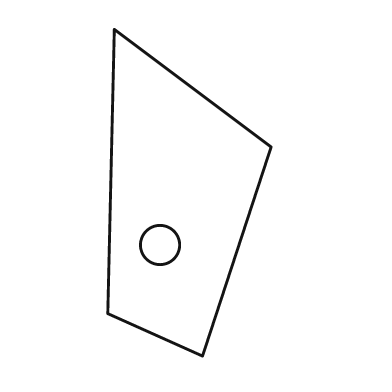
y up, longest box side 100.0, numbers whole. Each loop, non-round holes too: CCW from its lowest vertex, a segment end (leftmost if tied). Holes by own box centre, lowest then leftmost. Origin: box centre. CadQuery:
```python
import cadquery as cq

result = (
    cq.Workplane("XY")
    .moveTo(4.0, -50.0)
    .lineTo(25.0, 14.0)
    .lineTo(-23.0, 50.0)
    .lineTo(-25.0, -37.0)
    .close()
    .moveTo(-9.0, -16.0)
    .circle(6.0)
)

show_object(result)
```